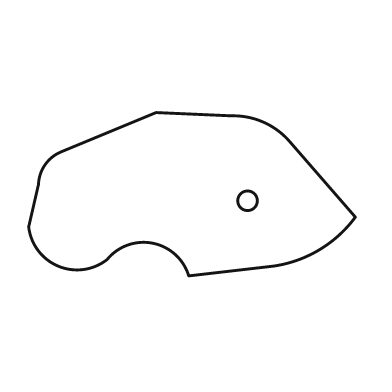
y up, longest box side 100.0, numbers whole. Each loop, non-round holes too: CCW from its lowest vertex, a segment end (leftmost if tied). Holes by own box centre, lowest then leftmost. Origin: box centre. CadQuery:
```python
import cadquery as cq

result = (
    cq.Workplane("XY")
    .moveTo(-1.0, -25.0)
    .lineTo(25.0, -22.0)
    .threePointArc((39.0, -17.0), (50.0, -7.0))
    .lineTo(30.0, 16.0)
    .threePointArc((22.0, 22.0), (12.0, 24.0))
    .lineTo(-11.0, 25.0)
    .lineTo(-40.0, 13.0)
    .threePointArc((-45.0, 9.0), (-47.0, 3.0))
    .lineTo(-50.0, -10.0)
    .threePointArc((-41.0, -22.0), (-26.0, -20.0))
    .threePointArc((-12.0, -15.0), (-1.0, -25.0))
    .close()
    .moveTo(17.0, -2.0)
    .circle(3.0)
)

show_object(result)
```